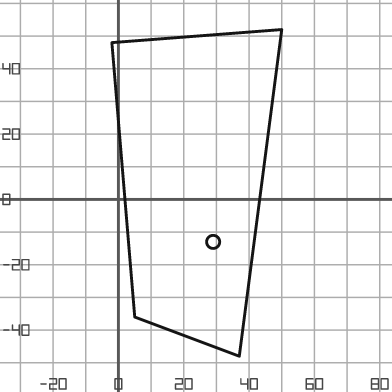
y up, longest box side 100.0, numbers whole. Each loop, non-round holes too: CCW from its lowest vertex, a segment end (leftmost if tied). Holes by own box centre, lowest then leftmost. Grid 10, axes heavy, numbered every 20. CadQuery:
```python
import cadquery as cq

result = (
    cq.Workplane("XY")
    .moveTo(37.0, -48.0)
    .lineTo(50.0, 52.0)
    .lineTo(-2.0, 48.0)
    .lineTo(5.0, -36.0)
    .close()
    .moveTo(29.0, -13.0)
    .circle(2.0)
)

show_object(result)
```